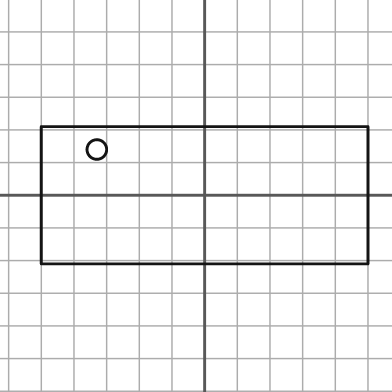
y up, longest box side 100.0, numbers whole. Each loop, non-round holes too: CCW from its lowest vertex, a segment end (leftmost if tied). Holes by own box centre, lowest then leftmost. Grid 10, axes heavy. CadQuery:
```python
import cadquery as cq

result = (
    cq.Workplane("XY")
    .moveTo(-50.0, -21.0)
    .lineTo(50.0, -21.0)
    .lineTo(50.0, 21.0)
    .lineTo(-50.0, 21.0)
    .close()
    .moveTo(-33.0, 14.0)
    .circle(3.0)
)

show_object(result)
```